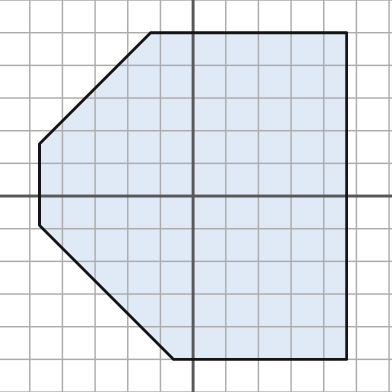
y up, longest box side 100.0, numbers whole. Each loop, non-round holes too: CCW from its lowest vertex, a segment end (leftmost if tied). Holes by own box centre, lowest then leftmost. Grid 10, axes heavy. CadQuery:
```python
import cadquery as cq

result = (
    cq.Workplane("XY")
    .moveTo(-6.0, -50.0)
    .lineTo(47.0, -50.0)
    .lineTo(47.0, 50.0)
    .lineTo(-13.0, 50.0)
    .lineTo(-47.0, 16.0)
    .lineTo(-47.0, -9.0)
    .close()
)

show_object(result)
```